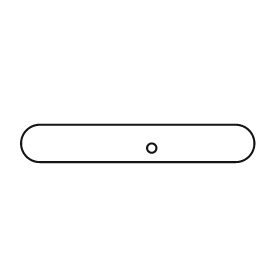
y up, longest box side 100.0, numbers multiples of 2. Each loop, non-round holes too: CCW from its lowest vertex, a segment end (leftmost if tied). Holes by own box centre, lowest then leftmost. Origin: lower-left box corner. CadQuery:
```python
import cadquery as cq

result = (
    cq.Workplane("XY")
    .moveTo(8.0, 0.0)
    .lineTo(92.0, 0.0)
    .threePointArc((100.0, 8.0), (92.0, 16.0))
    .lineTo(8.0, 16.0)
    .threePointArc((0.0, 8.0), (8.0, 0.0))
    .close()
    .moveTo(56.0, 6.0)
    .circle(2.0)
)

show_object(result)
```